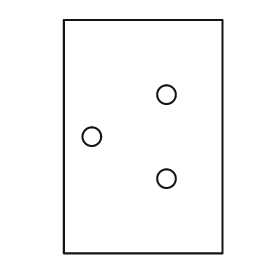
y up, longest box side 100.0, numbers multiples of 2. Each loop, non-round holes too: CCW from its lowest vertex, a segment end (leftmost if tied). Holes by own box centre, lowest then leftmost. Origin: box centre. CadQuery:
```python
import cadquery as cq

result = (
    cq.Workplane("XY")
    .moveTo(-34.0, -50.0)
    .lineTo(34.0, -50.0)
    .lineTo(34.0, 50.0)
    .lineTo(-34.0, 50.0)
    .close()
    .moveTo(10.0, -18.0)
    .circle(4.0)
    .moveTo(-22.0, 0.0)
    .circle(4.0)
    .moveTo(10.0, 18.0)
    .circle(4.0)
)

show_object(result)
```